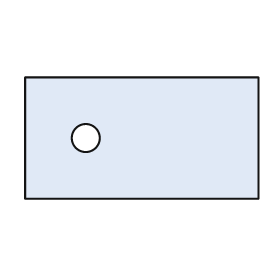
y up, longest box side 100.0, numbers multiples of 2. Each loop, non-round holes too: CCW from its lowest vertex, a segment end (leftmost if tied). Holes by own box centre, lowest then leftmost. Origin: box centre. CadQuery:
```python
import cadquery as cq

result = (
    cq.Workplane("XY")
    .moveTo(-50.0, -26.0)
    .lineTo(50.0, -26.0)
    .lineTo(50.0, 26.0)
    .lineTo(-50.0, 26.0)
    .close()
    .moveTo(-24.0, 0.0)
    .circle(6.0)
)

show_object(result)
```